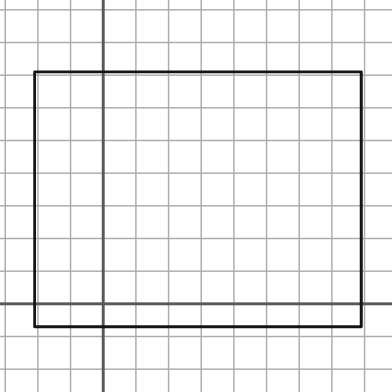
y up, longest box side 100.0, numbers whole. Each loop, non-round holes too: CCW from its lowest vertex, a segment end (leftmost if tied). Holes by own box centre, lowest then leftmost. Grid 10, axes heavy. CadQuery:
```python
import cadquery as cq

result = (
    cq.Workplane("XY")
    .moveTo(-21.0, -7.0)
    .lineTo(79.0, -7.0)
    .lineTo(79.0, 71.0)
    .lineTo(-21.0, 71.0)
    .close()
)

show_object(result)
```